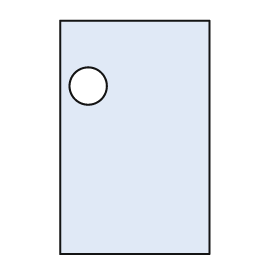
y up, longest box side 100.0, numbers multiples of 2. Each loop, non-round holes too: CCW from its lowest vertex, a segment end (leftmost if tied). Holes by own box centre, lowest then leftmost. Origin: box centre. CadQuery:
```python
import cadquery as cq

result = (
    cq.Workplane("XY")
    .moveTo(-32.0, -50.0)
    .lineTo(32.0, -50.0)
    .lineTo(32.0, 50.0)
    .lineTo(-32.0, 50.0)
    .close()
    .moveTo(-20.0, 22.0)
    .circle(8.0)
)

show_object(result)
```